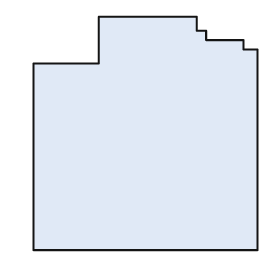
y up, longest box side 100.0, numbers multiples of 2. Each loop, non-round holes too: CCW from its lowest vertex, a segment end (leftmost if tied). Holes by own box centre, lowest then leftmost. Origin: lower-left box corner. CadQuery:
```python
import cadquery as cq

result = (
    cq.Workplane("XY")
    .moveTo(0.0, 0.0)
    .lineTo(96.0, 0.0)
    .lineTo(96.0, 86.0)
    .lineTo(90.0, 86.0)
    .lineTo(90.0, 90.0)
    .lineTo(74.0, 90.0)
    .lineTo(74.0, 94.0)
    .lineTo(70.0, 94.0)
    .lineTo(70.0, 100.0)
    .lineTo(28.0, 100.0)
    .lineTo(28.0, 80.0)
    .lineTo(0.0, 80.0)
    .close()
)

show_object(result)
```